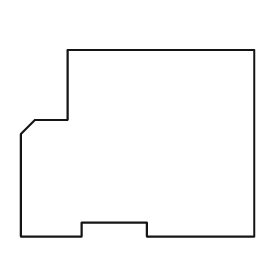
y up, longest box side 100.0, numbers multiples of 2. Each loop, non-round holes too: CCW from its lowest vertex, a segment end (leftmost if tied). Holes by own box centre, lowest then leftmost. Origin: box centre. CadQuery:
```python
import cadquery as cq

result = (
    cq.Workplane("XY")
    .moveTo(-50.0, -40.0)
    .lineTo(-24.0, -40.0)
    .lineTo(-24.0, -34.0)
    .lineTo(4.0, -34.0)
    .lineTo(4.0, -40.0)
    .lineTo(50.0, -40.0)
    .lineTo(50.0, 40.0)
    .lineTo(-30.0, 40.0)
    .lineTo(-30.0, 10.0)
    .lineTo(-44.0, 10.0)
    .lineTo(-50.0, 4.0)
    .close()
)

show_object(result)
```